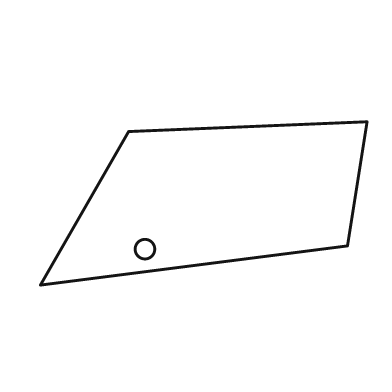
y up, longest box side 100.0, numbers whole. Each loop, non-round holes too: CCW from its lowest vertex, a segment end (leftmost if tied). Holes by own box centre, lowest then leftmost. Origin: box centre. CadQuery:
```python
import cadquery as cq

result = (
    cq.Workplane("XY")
    .moveTo(-50.0, -25.0)
    .lineTo(44.0, -13.0)
    .lineTo(50.0, 25.0)
    .lineTo(-23.0, 22.0)
    .close()
    .moveTo(-18.0, -14.0)
    .circle(3.0)
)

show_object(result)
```